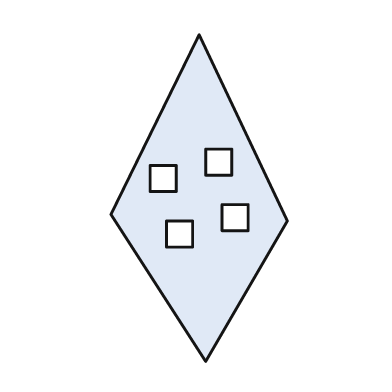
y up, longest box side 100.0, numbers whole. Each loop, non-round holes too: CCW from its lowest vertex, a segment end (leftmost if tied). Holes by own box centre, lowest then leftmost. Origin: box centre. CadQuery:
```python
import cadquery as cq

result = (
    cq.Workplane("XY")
    .moveTo(2.0, -50.0)
    .lineTo(27.0, -7.0)
    .lineTo(0.0, 50.0)
    .lineTo(-27.0, -5.0)
    .close()
    .moveTo(-10.0, -15.0)
    .lineTo(-2.0, -15.0)
    .lineTo(-2.0, -7.0)
    .lineTo(-10.0, -7.0)
    .close()
    .moveTo(7.0, -10.0)
    .lineTo(15.0, -10.0)
    .lineTo(15.0, -2.0)
    .lineTo(7.0, -2.0)
    .close()
    .moveTo(-15.0, 2.0)
    .lineTo(-7.0, 2.0)
    .lineTo(-7.0, 10.0)
    .lineTo(-15.0, 10.0)
    .close()
    .moveTo(2.0, 7.0)
    .lineTo(10.0, 7.0)
    .lineTo(10.0, 15.0)
    .lineTo(2.0, 15.0)
    .close()
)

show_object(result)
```